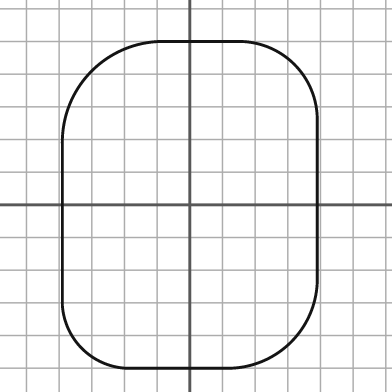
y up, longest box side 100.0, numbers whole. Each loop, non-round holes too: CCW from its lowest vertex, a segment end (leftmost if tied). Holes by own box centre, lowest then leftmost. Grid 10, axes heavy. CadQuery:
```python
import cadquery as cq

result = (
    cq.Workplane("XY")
    .moveTo(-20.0, -50.0)
    .lineTo(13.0, -50.0)
    .threePointArc((31.0, -42.0), (39.0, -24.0))
    .lineTo(39.0, 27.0)
    .threePointArc((32.0, 43.0), (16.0, 50.0))
    .lineTo(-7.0, 50.0)
    .threePointArc((-30.0, 41.0), (-39.0, 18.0))
    .lineTo(-39.0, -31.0)
    .threePointArc((-33.0, -44.0), (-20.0, -50.0))
    .close()
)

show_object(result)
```